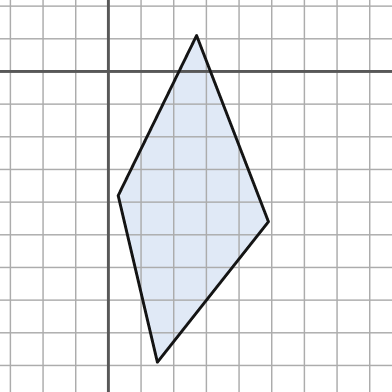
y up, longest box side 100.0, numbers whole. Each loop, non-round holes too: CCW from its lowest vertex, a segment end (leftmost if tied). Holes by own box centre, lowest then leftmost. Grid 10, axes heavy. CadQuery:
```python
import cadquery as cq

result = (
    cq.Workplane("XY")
    .moveTo(15.0, -89.0)
    .lineTo(49.0, -46.0)
    .lineTo(27.0, 11.0)
    .lineTo(3.0, -38.0)
    .close()
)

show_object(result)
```